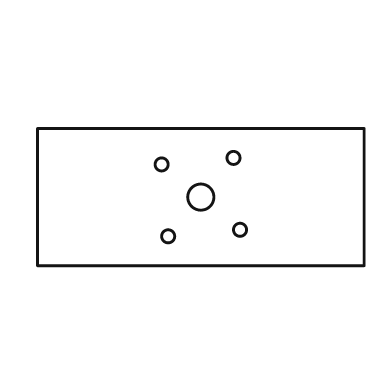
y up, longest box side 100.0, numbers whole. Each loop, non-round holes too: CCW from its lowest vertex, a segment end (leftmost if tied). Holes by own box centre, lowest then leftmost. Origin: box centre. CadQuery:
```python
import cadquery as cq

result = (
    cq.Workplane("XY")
    .moveTo(-50.0, -21.0)
    .lineTo(50.0, -21.0)
    .lineTo(50.0, 21.0)
    .lineTo(-50.0, 21.0)
    .close()
    .moveTo(-10.0, -12.0)
    .circle(2.0)
    .moveTo(12.0, -10.0)
    .circle(2.0)
    .moveTo(0.0, 0.0)
    .circle(4.0)
    .moveTo(-12.0, 10.0)
    .circle(2.0)
    .moveTo(10.0, 12.0)
    .circle(2.0)
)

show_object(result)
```